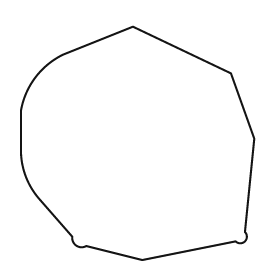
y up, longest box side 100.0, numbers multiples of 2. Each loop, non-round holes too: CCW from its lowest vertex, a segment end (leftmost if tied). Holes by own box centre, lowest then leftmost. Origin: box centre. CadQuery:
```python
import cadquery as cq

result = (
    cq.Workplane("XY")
    .moveTo(2.0, -50.0)
    .lineTo(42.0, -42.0)
    .threePointArc((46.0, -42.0), (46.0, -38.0))
    .lineTo(50.0, 2.0)
    .lineTo(40.0, 30.0)
    .lineTo(-2.0, 50.0)
    .lineTo(-32.0, 38.0)
    .threePointArc((-44.0, 28.0), (-50.0, 14.0))
    .lineTo(-50.0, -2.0)
    .threePointArc((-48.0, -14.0), (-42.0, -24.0))
    .lineTo(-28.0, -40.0)
    .threePointArc((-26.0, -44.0), (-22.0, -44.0))
    .close()
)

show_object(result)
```